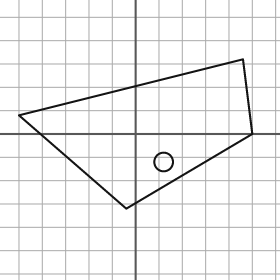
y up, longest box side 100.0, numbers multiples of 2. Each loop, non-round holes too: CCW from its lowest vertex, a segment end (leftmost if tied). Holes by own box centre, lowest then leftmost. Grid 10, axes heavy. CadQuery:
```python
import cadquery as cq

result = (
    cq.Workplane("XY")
    .moveTo(-4.0, -32.0)
    .lineTo(50.0, 0.0)
    .lineTo(46.0, 32.0)
    .lineTo(-50.0, 8.0)
    .close()
    .moveTo(12.0, -12.0)
    .circle(4.0)
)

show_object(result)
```